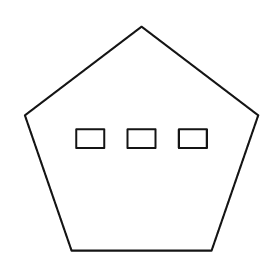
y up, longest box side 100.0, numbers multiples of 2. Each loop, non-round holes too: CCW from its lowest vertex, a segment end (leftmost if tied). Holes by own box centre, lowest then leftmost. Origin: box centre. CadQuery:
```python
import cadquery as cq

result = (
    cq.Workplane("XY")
    .moveTo(-30.0, -48.0)
    .lineTo(30.0, -48.0)
    .lineTo(50.0, 10.0)
    .lineTo(0.0, 48.0)
    .lineTo(-50.0, 10.0)
    .close()
    .moveTo(-28.0, -4.0)
    .lineTo(-16.0, -4.0)
    .lineTo(-16.0, 4.0)
    .lineTo(-28.0, 4.0)
    .close()
    .moveTo(-6.0, -4.0)
    .lineTo(6.0, -4.0)
    .lineTo(6.0, 4.0)
    .lineTo(-6.0, 4.0)
    .close()
    .moveTo(16.0, -4.0)
    .lineTo(28.0, -4.0)
    .lineTo(28.0, 4.0)
    .lineTo(16.0, 4.0)
    .close()
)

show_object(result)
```